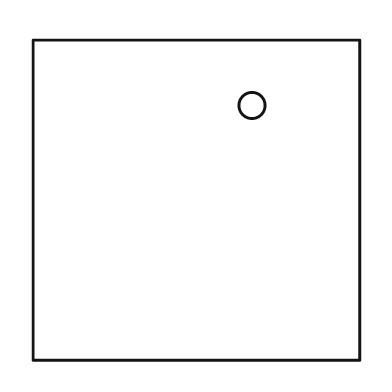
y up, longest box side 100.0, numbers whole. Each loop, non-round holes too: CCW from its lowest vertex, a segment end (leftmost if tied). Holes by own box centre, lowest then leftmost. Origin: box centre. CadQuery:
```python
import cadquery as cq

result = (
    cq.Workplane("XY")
    .moveTo(-50.0, -49.0)
    .lineTo(50.0, -49.0)
    .lineTo(50.0, 49.0)
    .lineTo(-50.0, 49.0)
    .close()
    .moveTo(17.0, 29.0)
    .circle(4.0)
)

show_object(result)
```